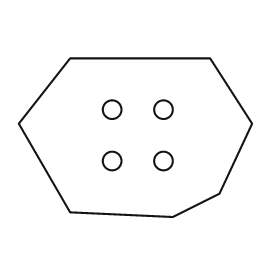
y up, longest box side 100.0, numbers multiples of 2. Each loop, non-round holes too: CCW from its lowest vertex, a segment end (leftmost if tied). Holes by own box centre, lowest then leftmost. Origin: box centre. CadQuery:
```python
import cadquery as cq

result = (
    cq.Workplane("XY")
    .moveTo(16.0, -34.0)
    .lineTo(36.0, -24.0)
    .lineTo(50.0, 6.0)
    .lineTo(32.0, 34.0)
    .lineTo(-28.0, 34.0)
    .lineTo(-50.0, 6.0)
    .lineTo(-28.0, -32.0)
    .close()
    .moveTo(-10.0, -10.0)
    .circle(4.0)
    .moveTo(12.0, -10.0)
    .circle(4.0)
    .moveTo(-10.0, 12.0)
    .circle(4.0)
    .moveTo(12.0, 12.0)
    .circle(4.0)
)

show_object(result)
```